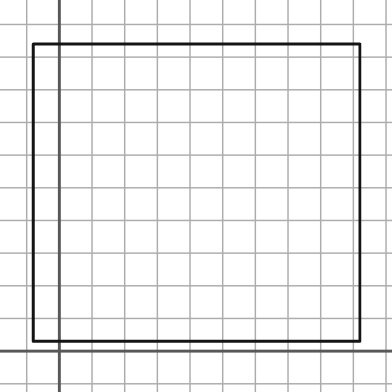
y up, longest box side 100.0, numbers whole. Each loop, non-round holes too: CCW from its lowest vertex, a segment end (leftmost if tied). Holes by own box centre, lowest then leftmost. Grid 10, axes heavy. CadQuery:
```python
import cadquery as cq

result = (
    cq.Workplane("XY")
    .moveTo(-8.0, 3.0)
    .lineTo(92.0, 3.0)
    .lineTo(92.0, 94.0)
    .lineTo(-8.0, 94.0)
    .close()
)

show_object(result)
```